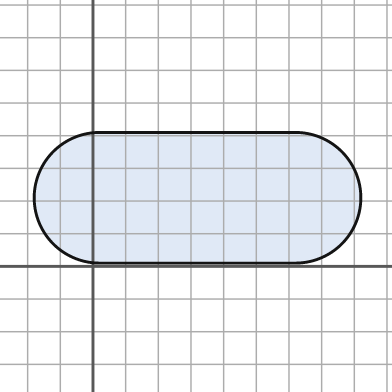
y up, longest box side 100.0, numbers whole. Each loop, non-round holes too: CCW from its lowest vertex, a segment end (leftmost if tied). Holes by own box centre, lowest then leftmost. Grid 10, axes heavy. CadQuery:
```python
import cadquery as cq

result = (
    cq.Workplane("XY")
    .moveTo(2.0, 1.0)
    .lineTo(62.0, 1.0)
    .threePointArc((82.0, 21.0), (62.0, 41.0))
    .lineTo(2.0, 41.0)
    .threePointArc((-18.0, 21.0), (2.0, 1.0))
    .close()
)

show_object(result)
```